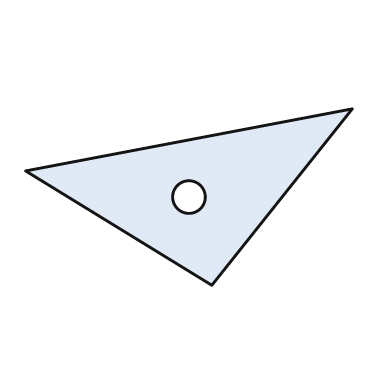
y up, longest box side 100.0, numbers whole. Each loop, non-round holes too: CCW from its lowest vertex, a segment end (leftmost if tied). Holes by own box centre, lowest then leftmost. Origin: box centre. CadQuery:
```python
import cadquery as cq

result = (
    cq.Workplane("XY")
    .moveTo(7.0, -27.0)
    .lineTo(50.0, 27.0)
    .lineTo(-50.0, 8.0)
    .close()
    .moveTo(0.0, 0.0)
    .circle(5.0)
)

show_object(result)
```